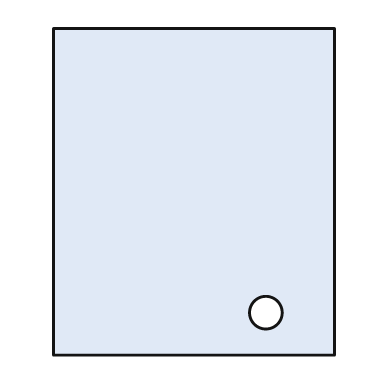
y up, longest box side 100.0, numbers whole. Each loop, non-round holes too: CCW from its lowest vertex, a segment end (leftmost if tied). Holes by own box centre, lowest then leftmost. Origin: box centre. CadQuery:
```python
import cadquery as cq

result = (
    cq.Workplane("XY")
    .moveTo(-43.0, -50.0)
    .lineTo(43.0, -50.0)
    .lineTo(43.0, 50.0)
    .lineTo(-43.0, 50.0)
    .close()
    .moveTo(22.0, -37.0)
    .circle(5.0)
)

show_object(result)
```